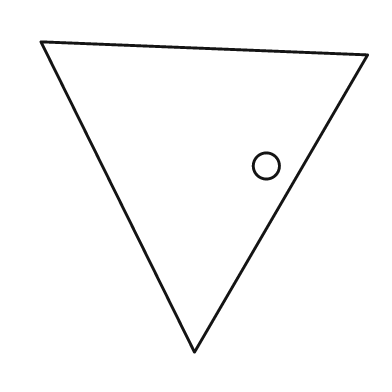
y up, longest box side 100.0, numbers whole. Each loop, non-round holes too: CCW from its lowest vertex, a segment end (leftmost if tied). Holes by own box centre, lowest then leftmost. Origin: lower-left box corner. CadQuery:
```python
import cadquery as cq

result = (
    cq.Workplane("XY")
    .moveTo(47.0, 0.0)
    .lineTo(100.0, 91.0)
    .lineTo(0.0, 95.0)
    .close()
    .moveTo(69.0, 57.0)
    .circle(4.0)
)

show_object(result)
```